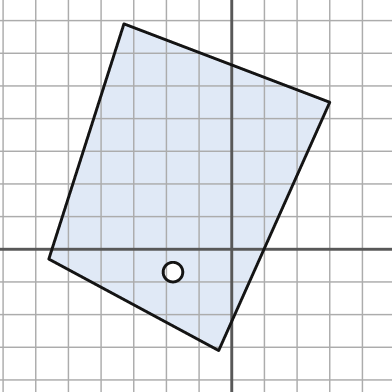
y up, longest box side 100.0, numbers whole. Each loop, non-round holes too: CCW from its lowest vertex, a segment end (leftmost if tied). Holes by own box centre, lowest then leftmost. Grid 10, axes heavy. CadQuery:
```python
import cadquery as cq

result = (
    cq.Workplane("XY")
    .moveTo(-4.0, -31.0)
    .lineTo(30.0, 45.0)
    .lineTo(-33.0, 69.0)
    .lineTo(-56.0, -3.0)
    .close()
    .moveTo(-18.0, -7.0)
    .circle(3.0)
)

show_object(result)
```